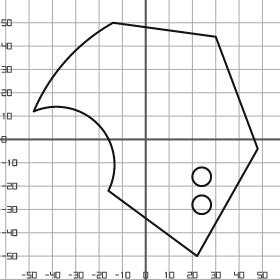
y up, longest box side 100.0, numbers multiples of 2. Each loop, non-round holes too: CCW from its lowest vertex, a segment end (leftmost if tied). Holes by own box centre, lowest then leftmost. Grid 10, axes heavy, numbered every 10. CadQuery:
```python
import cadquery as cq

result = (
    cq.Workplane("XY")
    .moveTo(22.0, -50.0)
    .lineTo(48.0, -4.0)
    .lineTo(30.0, 44.0)
    .lineTo(-14.0, 50.0)
    .threePointArc((-34.0, 34.0), (-48.0, 12.0))
    .threePointArc((-20.0, 6.0), (-16.0, -22.0))
    .close()
    .moveTo(24.0, -28.0)
    .circle(4.0)
    .moveTo(24.0, -16.0)
    .circle(4.0)
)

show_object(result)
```